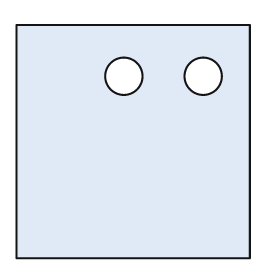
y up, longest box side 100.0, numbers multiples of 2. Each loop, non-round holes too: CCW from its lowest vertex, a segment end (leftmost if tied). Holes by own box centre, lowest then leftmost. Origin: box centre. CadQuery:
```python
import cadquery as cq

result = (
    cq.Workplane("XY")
    .moveTo(-50.0, -50.0)
    .lineTo(50.0, -50.0)
    .lineTo(50.0, 50.0)
    .lineTo(-50.0, 50.0)
    .close()
    .moveTo(-4.0, 28.0)
    .circle(8.0)
    .moveTo(30.0, 28.0)
    .circle(8.0)
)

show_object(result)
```